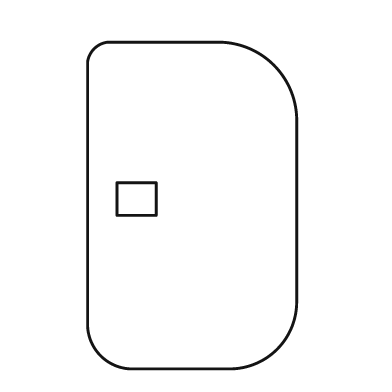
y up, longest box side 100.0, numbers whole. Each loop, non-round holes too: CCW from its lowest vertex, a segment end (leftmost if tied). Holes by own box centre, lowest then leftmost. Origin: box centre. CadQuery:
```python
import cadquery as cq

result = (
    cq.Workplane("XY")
    .moveTo(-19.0, -50.0)
    .lineTo(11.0, -50.0)
    .threePointArc((26.0, -44.0), (32.0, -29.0))
    .lineTo(32.0, 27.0)
    .threePointArc((25.0, 43.0), (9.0, 50.0))
    .lineTo(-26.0, 50.0)
    .threePointArc((-30.0, 48.0), (-32.0, 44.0))
    .lineTo(-32.0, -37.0)
    .threePointArc((-28.0, -46.0), (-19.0, -50.0))
    .close()
    .moveTo(-23.0, -3.0)
    .lineTo(-11.0, -3.0)
    .lineTo(-11.0, 7.0)
    .lineTo(-23.0, 7.0)
    .close()
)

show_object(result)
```